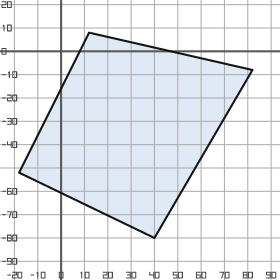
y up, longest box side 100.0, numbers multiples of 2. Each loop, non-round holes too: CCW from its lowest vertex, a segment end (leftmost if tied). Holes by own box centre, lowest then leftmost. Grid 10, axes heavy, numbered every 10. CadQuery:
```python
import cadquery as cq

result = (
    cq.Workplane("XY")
    .moveTo(40.0, -80.0)
    .lineTo(82.0, -8.0)
    .lineTo(12.0, 8.0)
    .lineTo(-18.0, -52.0)
    .close()
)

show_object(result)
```